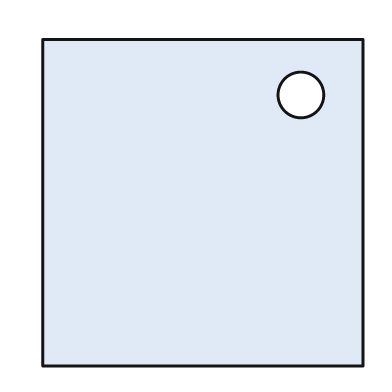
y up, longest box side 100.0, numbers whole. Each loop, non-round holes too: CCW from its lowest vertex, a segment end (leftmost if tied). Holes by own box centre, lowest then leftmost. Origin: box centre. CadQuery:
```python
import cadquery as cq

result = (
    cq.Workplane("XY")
    .moveTo(-49.0, -50.0)
    .lineTo(49.0, -50.0)
    .lineTo(49.0, 50.0)
    .lineTo(-49.0, 50.0)
    .close()
    .moveTo(30.0, 33.0)
    .circle(7.0)
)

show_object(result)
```